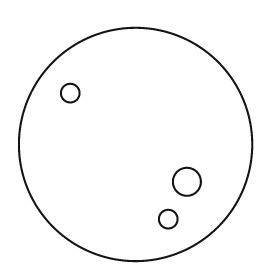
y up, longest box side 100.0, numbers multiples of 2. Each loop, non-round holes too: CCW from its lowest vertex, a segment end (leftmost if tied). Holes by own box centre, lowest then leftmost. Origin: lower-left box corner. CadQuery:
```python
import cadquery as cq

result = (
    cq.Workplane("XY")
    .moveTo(50.0, 50.0)
    .circle(50.0)
    .moveTo(64.0, 18.0)
    .circle(4.0)
    .moveTo(72.0, 34.0)
    .circle(6.0)
    .moveTo(22.0, 72.0)
    .circle(4.0)
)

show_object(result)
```